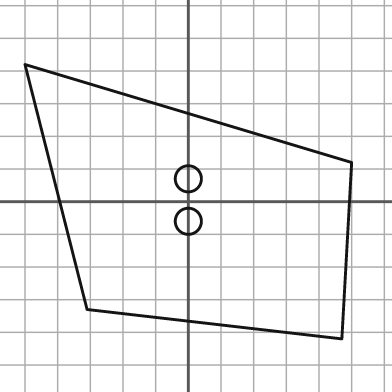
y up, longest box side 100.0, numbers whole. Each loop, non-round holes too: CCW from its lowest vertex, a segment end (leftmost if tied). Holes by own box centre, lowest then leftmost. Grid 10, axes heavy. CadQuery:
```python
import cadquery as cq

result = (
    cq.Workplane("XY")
    .moveTo(47.0, -42.0)
    .lineTo(50.0, 12.0)
    .lineTo(-50.0, 42.0)
    .lineTo(-31.0, -33.0)
    .close()
    .moveTo(0.0, -6.0)
    .circle(4.0)
    .moveTo(0.0, 7.0)
    .circle(4.0)
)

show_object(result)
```